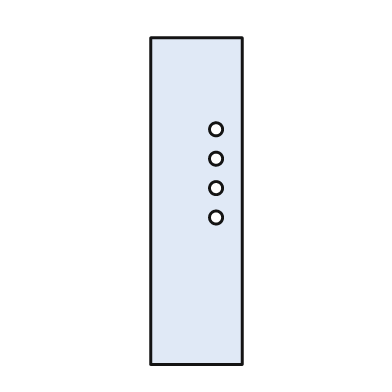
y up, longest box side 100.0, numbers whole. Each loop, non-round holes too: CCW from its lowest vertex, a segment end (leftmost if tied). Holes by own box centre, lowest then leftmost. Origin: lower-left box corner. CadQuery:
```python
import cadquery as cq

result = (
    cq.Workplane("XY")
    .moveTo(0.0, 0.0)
    .lineTo(28.0, 0.0)
    .lineTo(28.0, 100.0)
    .lineTo(0.0, 100.0)
    .close()
    .moveTo(20.0, 45.0)
    .circle(2.0)
    .moveTo(20.0, 54.0)
    .circle(2.0)
    .moveTo(20.0, 63.0)
    .circle(2.0)
    .moveTo(20.0, 72.0)
    .circle(2.0)
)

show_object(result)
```